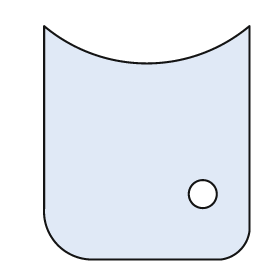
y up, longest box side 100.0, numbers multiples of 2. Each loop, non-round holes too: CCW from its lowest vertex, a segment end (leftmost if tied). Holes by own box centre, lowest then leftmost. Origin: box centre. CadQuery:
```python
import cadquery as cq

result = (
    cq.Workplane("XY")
    .moveTo(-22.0, -50.0)
    .lineTo(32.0, -50.0)
    .threePointArc((40.0, -46.0), (44.0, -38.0))
    .lineTo(44.0, 50.0)
    .threePointArc((0.0, 34.0), (-44.0, 50.0))
    .lineTo(-44.0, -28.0)
    .threePointArc((-38.0, -44.0), (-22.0, -50.0))
    .close()
    .moveTo(24.0, -22.0)
    .circle(6.0)
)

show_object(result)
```